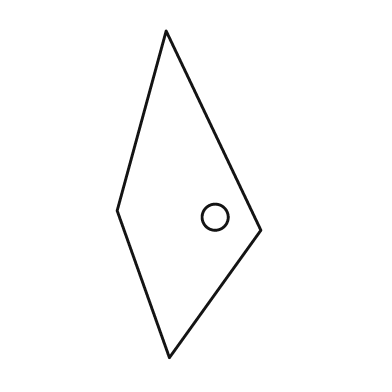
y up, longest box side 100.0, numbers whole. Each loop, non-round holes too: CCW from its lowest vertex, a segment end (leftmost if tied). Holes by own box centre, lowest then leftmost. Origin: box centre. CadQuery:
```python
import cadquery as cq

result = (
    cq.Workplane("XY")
    .moveTo(-6.0, -50.0)
    .lineTo(22.0, -11.0)
    .lineTo(-7.0, 50.0)
    .lineTo(-22.0, -5.0)
    .close()
    .moveTo(8.0, -7.0)
    .circle(4.0)
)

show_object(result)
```